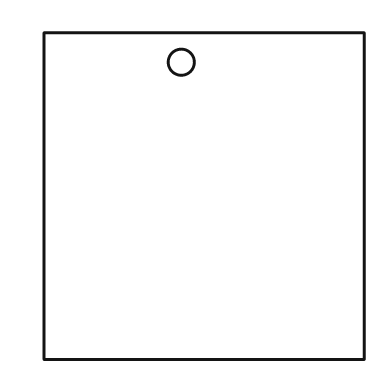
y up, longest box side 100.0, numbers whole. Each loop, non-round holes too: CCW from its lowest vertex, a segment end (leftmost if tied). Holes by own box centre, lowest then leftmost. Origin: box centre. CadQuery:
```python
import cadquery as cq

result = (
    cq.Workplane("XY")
    .moveTo(-49.0, -50.0)
    .lineTo(49.0, -50.0)
    .lineTo(49.0, 50.0)
    .lineTo(-49.0, 50.0)
    .close()
    .moveTo(-7.0, 41.0)
    .circle(4.0)
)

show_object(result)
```